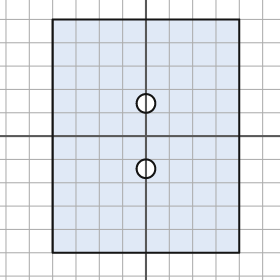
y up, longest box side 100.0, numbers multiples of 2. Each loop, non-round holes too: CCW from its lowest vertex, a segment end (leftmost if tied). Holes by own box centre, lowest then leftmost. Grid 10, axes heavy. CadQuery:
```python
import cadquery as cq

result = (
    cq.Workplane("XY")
    .moveTo(-40.0, -50.0)
    .lineTo(40.0, -50.0)
    .lineTo(40.0, 50.0)
    .lineTo(-40.0, 50.0)
    .close()
    .moveTo(0.0, -14.0)
    .circle(4.0)
    .moveTo(0.0, 14.0)
    .circle(4.0)
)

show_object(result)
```